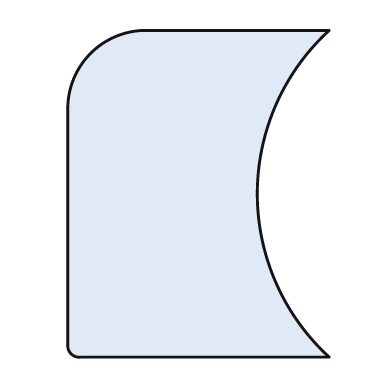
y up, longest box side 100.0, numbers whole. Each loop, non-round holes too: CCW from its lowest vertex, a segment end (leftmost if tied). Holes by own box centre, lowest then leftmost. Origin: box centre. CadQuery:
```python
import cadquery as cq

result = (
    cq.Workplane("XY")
    .moveTo(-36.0, -50.0)
    .lineTo(40.0, -50.0)
    .threePointArc((18.0, 0.0), (40.0, 50.0))
    .lineTo(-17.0, 50.0)
    .threePointArc((-33.0, 43.0), (-40.0, 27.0))
    .lineTo(-40.0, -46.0)
    .threePointArc((-39.0, -49.0), (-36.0, -50.0))
    .close()
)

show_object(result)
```